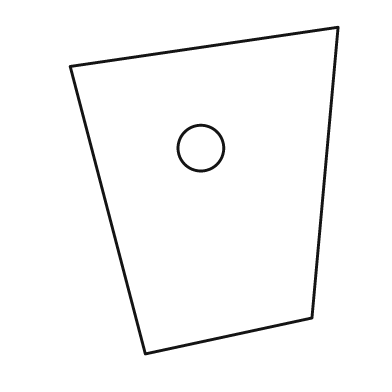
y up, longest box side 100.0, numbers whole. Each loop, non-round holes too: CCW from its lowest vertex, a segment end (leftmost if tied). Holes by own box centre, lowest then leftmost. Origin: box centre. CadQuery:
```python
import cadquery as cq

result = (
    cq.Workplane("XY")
    .moveTo(-18.0, -50.0)
    .lineTo(33.0, -39.0)
    .lineTo(41.0, 50.0)
    .lineTo(-41.0, 38.0)
    .close()
    .moveTo(-1.0, 13.0)
    .circle(7.0)
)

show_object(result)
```